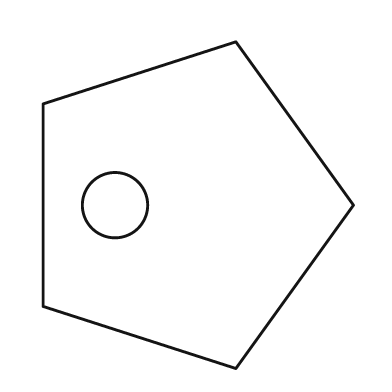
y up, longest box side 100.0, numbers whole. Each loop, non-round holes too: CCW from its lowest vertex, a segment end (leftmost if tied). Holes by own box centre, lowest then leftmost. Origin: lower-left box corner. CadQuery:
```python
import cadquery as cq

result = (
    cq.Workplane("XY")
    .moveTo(59.0, 0.0)
    .lineTo(95.0, 50.0)
    .lineTo(59.0, 100.0)
    .lineTo(0.0, 81.0)
    .lineTo(0.0, 19.0)
    .close()
    .moveTo(22.0, 50.0)
    .circle(10.0)
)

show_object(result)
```